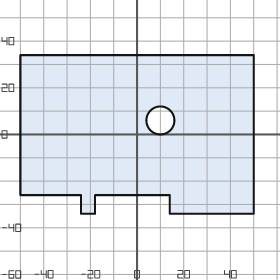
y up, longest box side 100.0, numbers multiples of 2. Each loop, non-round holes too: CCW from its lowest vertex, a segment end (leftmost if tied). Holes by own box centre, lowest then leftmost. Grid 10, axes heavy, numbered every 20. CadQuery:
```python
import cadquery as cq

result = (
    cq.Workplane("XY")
    .moveTo(-24.0, -34.0)
    .lineTo(-18.0, -34.0)
    .lineTo(-18.0, -26.0)
    .lineTo(14.0, -26.0)
    .lineTo(14.0, -34.0)
    .lineTo(50.0, -34.0)
    .lineTo(50.0, 34.0)
    .lineTo(-50.0, 34.0)
    .lineTo(-50.0, -26.0)
    .lineTo(-24.0, -26.0)
    .close()
    .moveTo(10.0, 6.0)
    .circle(6.0)
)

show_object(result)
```